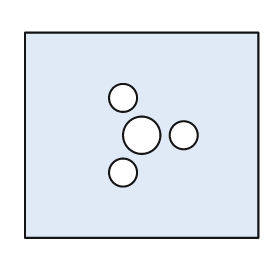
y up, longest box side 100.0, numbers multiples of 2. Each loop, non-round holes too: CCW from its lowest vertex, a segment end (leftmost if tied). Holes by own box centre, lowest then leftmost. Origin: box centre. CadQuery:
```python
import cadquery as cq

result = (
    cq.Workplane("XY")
    .moveTo(-50.0, -44.0)
    .lineTo(50.0, -44.0)
    .lineTo(50.0, 44.0)
    .lineTo(-50.0, 44.0)
    .close()
    .moveTo(-8.0, -16.0)
    .circle(6.0)
    .moveTo(0.0, 0.0)
    .circle(8.0)
    .moveTo(18.0, 0.0)
    .circle(6.0)
    .moveTo(-8.0, 16.0)
    .circle(6.0)
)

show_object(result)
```